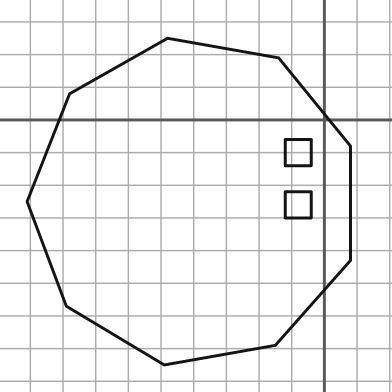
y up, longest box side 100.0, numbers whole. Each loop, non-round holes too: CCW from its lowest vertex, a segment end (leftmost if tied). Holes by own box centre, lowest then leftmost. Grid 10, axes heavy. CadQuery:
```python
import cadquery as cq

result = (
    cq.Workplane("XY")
    .moveTo(-49.0, -75.0)
    .lineTo(-15.0, -69.0)
    .lineTo(8.0, -43.0)
    .lineTo(8.0, -8.0)
    .lineTo(-14.0, 19.0)
    .lineTo(-48.0, 25.0)
    .lineTo(-78.0, 8.0)
    .lineTo(-91.0, -25.0)
    .lineTo(-79.0, -57.0)
    .close()
    .moveTo(-12.0, -30.0)
    .lineTo(-4.0, -30.0)
    .lineTo(-4.0, -22.0)
    .lineTo(-12.0, -22.0)
    .close()
    .moveTo(-12.0, -14.0)
    .lineTo(-4.0, -14.0)
    .lineTo(-4.0, -6.0)
    .lineTo(-12.0, -6.0)
    .close()
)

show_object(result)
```